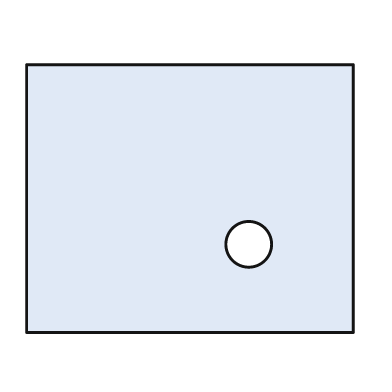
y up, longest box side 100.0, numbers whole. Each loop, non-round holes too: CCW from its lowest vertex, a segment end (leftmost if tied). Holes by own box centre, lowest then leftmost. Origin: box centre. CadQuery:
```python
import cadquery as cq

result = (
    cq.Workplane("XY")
    .moveTo(-50.0, -41.0)
    .lineTo(50.0, -41.0)
    .lineTo(50.0, 41.0)
    .lineTo(-50.0, 41.0)
    .close()
    .moveTo(18.0, -14.0)
    .circle(7.0)
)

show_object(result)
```